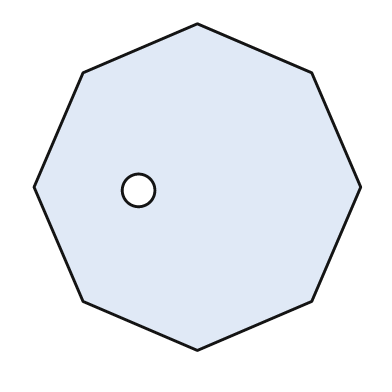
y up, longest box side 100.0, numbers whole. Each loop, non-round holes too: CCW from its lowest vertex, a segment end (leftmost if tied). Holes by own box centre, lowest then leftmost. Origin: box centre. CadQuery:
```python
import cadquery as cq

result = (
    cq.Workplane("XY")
    .moveTo(0.0, -50.0)
    .lineTo(35.0, -35.0)
    .lineTo(50.0, 0.0)
    .lineTo(35.0, 35.0)
    .lineTo(0.0, 50.0)
    .lineTo(-35.0, 35.0)
    .lineTo(-50.0, 0.0)
    .lineTo(-35.0, -35.0)
    .close()
    .moveTo(-18.0, -1.0)
    .circle(5.0)
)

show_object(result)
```